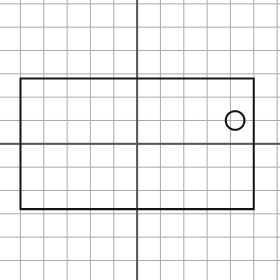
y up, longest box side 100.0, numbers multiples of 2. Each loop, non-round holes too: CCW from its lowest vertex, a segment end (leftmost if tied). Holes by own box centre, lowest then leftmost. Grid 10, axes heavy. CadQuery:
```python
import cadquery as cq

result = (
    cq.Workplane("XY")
    .moveTo(-50.0, -28.0)
    .lineTo(50.0, -28.0)
    .lineTo(50.0, 28.0)
    .lineTo(-50.0, 28.0)
    .close()
    .moveTo(42.0, 10.0)
    .circle(4.0)
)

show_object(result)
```